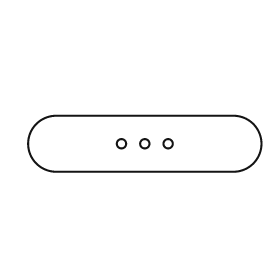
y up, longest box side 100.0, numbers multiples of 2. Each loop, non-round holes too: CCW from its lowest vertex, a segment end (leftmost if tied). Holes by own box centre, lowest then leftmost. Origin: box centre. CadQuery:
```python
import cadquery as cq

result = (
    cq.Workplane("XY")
    .moveTo(-38.0, -12.0)
    .lineTo(38.0, -12.0)
    .threePointArc((50.0, 0.0), (38.0, 12.0))
    .lineTo(-38.0, 12.0)
    .threePointArc((-50.0, 0.0), (-38.0, -12.0))
    .close()
    .moveTo(-10.0, 0.0)
    .circle(2.0)
    .moveTo(0.0, 0.0)
    .circle(2.0)
    .moveTo(10.0, 0.0)
    .circle(2.0)
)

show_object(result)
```